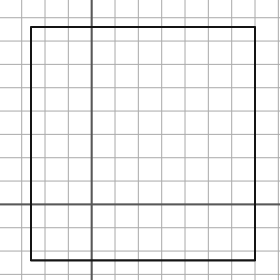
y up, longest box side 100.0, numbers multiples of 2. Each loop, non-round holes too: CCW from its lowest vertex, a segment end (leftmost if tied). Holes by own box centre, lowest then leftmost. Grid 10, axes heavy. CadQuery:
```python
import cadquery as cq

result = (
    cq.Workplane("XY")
    .moveTo(-26.0, -24.0)
    .lineTo(70.0, -24.0)
    .lineTo(70.0, 76.0)
    .lineTo(-26.0, 76.0)
    .close()
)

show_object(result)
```